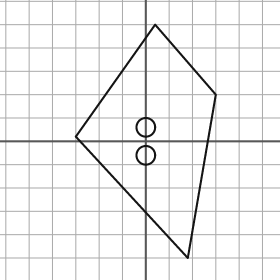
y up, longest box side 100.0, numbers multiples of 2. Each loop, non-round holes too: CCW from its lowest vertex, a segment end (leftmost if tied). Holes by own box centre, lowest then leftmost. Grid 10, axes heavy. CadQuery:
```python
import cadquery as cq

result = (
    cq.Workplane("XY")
    .moveTo(18.0, -50.0)
    .lineTo(30.0, 20.0)
    .lineTo(4.0, 50.0)
    .lineTo(-30.0, 2.0)
    .close()
    .moveTo(0.0, -6.0)
    .circle(4.0)
    .moveTo(0.0, 6.0)
    .circle(4.0)
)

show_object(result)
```